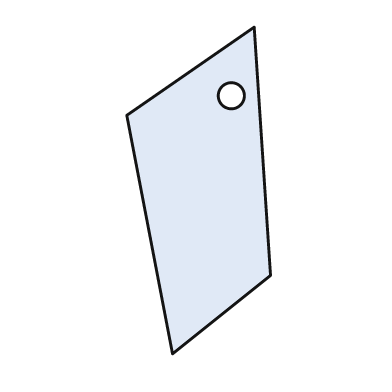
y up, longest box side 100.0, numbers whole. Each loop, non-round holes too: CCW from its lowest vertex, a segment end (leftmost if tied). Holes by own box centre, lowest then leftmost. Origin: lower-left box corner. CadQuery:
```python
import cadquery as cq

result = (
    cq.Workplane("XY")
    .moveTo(14.0, 0.0)
    .lineTo(44.0, 24.0)
    .lineTo(39.0, 100.0)
    .lineTo(0.0, 73.0)
    .close()
    .moveTo(32.0, 79.0)
    .circle(4.0)
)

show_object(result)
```